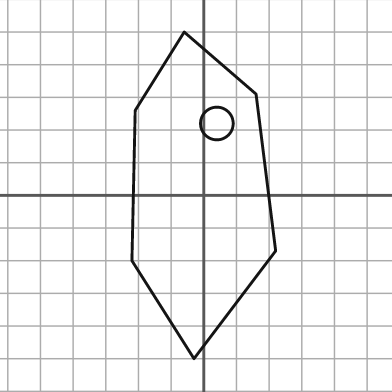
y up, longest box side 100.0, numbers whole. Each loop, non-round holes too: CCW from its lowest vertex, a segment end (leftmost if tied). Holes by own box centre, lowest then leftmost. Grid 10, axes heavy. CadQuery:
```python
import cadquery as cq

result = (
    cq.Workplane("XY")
    .moveTo(-3.0, -50.0)
    .lineTo(22.0, -17.0)
    .lineTo(16.0, 31.0)
    .lineTo(-6.0, 50.0)
    .lineTo(-21.0, 26.0)
    .lineTo(-22.0, -20.0)
    .close()
    .moveTo(4.0, 22.0)
    .circle(5.0)
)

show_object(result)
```